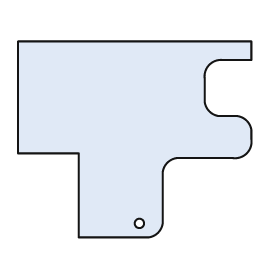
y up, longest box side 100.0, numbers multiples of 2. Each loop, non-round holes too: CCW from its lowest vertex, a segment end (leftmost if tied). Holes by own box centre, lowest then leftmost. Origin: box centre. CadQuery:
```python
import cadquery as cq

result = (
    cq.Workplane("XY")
    .moveTo(-24.0, -42.0)
    .lineTo(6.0, -42.0)
    .threePointArc((10.0, -40.0), (12.0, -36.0))
    .lineTo(12.0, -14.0)
    .threePointArc((14.0, -10.0), (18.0, -8.0))
    .lineTo(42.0, -8.0)
    .threePointArc((48.0, -6.0), (50.0, 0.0))
    .lineTo(50.0, 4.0)
    .threePointArc((48.0, 8.0), (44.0, 10.0))
    .lineTo(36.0, 10.0)
    .threePointArc((32.0, 12.0), (30.0, 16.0))
    .lineTo(30.0, 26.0)
    .threePointArc((32.0, 32.0), (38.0, 34.0))
    .lineTo(50.0, 34.0)
    .lineTo(50.0, 42.0)
    .lineTo(-50.0, 42.0)
    .lineTo(-50.0, -6.0)
    .lineTo(-24.0, -6.0)
    .close()
    .moveTo(2.0, -36.0)
    .circle(2.0)
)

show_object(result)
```